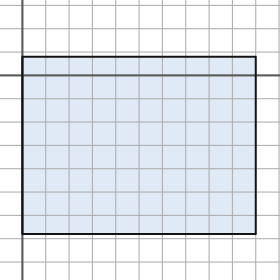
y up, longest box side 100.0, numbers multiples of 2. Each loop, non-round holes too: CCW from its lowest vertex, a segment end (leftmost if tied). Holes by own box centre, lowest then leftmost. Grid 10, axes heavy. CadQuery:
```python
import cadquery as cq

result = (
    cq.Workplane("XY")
    .moveTo(0.0, -68.0)
    .lineTo(100.0, -68.0)
    .lineTo(100.0, 8.0)
    .lineTo(0.0, 8.0)
    .close()
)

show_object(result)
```